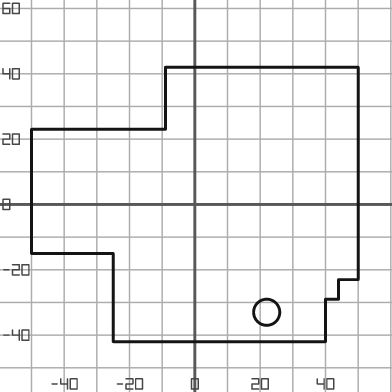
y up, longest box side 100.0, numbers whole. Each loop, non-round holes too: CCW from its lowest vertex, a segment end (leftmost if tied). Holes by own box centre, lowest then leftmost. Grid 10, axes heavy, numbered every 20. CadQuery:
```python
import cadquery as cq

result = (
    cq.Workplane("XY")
    .moveTo(-25.0, -42.0)
    .lineTo(40.0, -42.0)
    .lineTo(40.0, -29.0)
    .lineTo(44.0, -29.0)
    .lineTo(44.0, -23.0)
    .lineTo(50.0, -23.0)
    .lineTo(50.0, 42.0)
    .lineTo(-9.0, 42.0)
    .lineTo(-9.0, 23.0)
    .lineTo(-50.0, 23.0)
    .lineTo(-50.0, -15.0)
    .lineTo(-25.0, -15.0)
    .close()
    .moveTo(22.0, -33.0)
    .circle(4.0)
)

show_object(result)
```